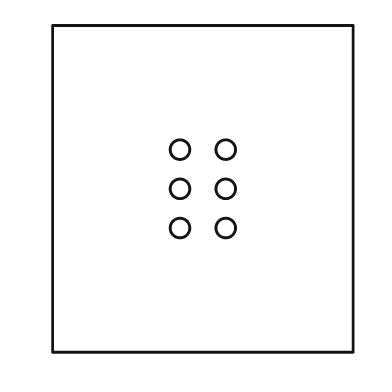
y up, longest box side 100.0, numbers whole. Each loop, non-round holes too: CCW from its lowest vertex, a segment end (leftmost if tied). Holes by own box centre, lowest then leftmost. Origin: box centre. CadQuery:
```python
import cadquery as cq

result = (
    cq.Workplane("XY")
    .moveTo(-46.0, -50.0)
    .lineTo(46.0, -50.0)
    .lineTo(46.0, 50.0)
    .lineTo(-46.0, 50.0)
    .close()
    .moveTo(-7.0, -12.0)
    .circle(3.0)
    .moveTo(7.0, -12.0)
    .circle(3.0)
    .moveTo(-7.0, 0.0)
    .circle(3.0)
    .moveTo(7.0, 0.0)
    .circle(3.0)
    .moveTo(-7.0, 12.0)
    .circle(3.0)
    .moveTo(7.0, 12.0)
    .circle(3.0)
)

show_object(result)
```